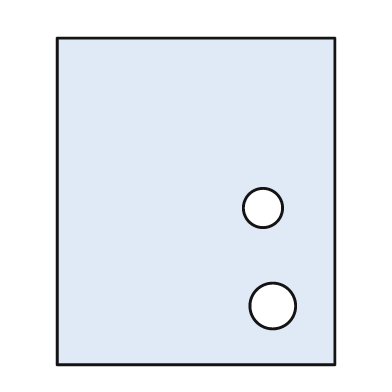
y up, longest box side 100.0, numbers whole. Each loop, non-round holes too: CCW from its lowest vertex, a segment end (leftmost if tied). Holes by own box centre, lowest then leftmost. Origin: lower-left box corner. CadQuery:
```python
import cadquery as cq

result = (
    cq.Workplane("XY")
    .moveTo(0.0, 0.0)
    .lineTo(85.0, 0.0)
    .lineTo(85.0, 100.0)
    .lineTo(0.0, 100.0)
    .close()
    .moveTo(66.0, 18.0)
    .circle(7.0)
    .moveTo(63.0, 48.0)
    .circle(6.0)
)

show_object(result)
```